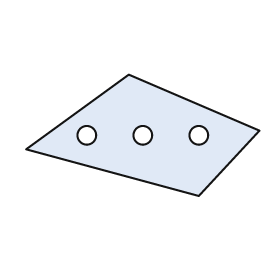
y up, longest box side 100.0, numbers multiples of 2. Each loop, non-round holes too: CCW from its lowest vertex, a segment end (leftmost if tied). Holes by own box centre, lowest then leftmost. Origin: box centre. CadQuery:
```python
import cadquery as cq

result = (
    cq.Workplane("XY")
    .moveTo(24.0, -26.0)
    .lineTo(50.0, 2.0)
    .lineTo(-6.0, 26.0)
    .lineTo(-50.0, -6.0)
    .close()
    .moveTo(-24.0, 0.0)
    .circle(4.0)
    .moveTo(0.0, 0.0)
    .circle(4.0)
    .moveTo(24.0, 0.0)
    .circle(4.0)
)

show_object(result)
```